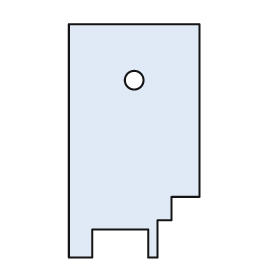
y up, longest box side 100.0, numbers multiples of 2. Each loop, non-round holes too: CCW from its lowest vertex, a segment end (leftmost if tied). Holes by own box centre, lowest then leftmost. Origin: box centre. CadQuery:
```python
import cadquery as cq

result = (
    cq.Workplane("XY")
    .moveTo(-28.0, -50.0)
    .lineTo(-18.0, -50.0)
    .lineTo(-18.0, -38.0)
    .lineTo(6.0, -38.0)
    .lineTo(6.0, -50.0)
    .lineTo(10.0, -50.0)
    .lineTo(10.0, -34.0)
    .lineTo(16.0, -34.0)
    .lineTo(16.0, -24.0)
    .lineTo(28.0, -24.0)
    .lineTo(28.0, 50.0)
    .lineTo(-28.0, 50.0)
    .close()
    .moveTo(0.0, 26.0)
    .circle(4.0)
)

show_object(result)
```